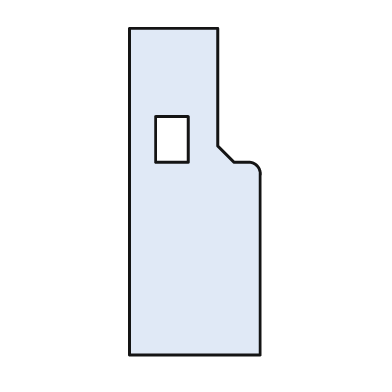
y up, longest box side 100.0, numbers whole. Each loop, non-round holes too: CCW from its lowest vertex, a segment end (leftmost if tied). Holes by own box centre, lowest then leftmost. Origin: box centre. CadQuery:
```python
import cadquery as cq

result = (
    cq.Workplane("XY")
    .moveTo(-20.0, -50.0)
    .lineTo(20.0, -50.0)
    .lineTo(20.0, 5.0)
    .threePointArc((19.0, 8.0), (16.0, 9.0))
    .lineTo(12.0, 9.0)
    .lineTo(7.0, 14.0)
    .lineTo(7.0, 50.0)
    .lineTo(-20.0, 50.0)
    .close()
    .moveTo(-12.0, 9.0)
    .lineTo(-2.0, 9.0)
    .lineTo(-2.0, 23.0)
    .lineTo(-12.0, 23.0)
    .close()
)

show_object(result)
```